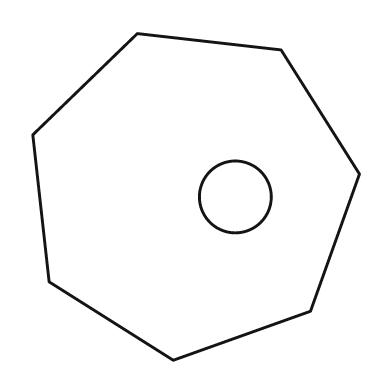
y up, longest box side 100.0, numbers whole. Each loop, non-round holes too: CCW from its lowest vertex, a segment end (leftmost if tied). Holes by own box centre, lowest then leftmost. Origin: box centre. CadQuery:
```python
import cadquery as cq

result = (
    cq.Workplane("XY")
    .moveTo(-7.0, -50.0)
    .lineTo(35.0, -35.0)
    .lineTo(50.0, 7.0)
    .lineTo(26.0, 45.0)
    .lineTo(-18.0, 50.0)
    .lineTo(-50.0, 19.0)
    .lineTo(-45.0, -26.0)
    .close()
    .moveTo(12.0, 0.0)
    .circle(11.0)
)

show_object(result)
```